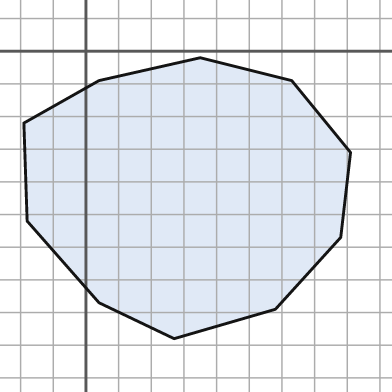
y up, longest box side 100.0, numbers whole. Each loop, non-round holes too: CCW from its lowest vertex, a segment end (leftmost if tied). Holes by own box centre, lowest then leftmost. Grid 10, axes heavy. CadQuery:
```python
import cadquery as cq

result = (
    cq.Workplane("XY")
    .moveTo(27.0, -88.0)
    .lineTo(58.0, -79.0)
    .lineTo(78.0, -57.0)
    .lineTo(81.0, -31.0)
    .lineTo(63.0, -9.0)
    .lineTo(35.0, -2.0)
    .lineTo(4.0, -9.0)
    .lineTo(-19.0, -22.0)
    .lineTo(-18.0, -52.0)
    .lineTo(4.0, -77.0)
    .close()
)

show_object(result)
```